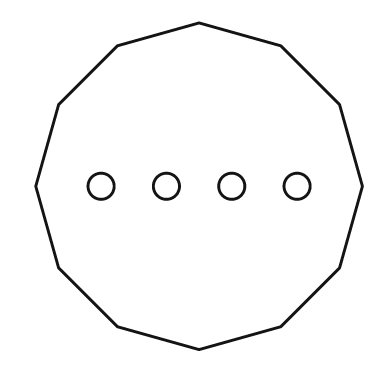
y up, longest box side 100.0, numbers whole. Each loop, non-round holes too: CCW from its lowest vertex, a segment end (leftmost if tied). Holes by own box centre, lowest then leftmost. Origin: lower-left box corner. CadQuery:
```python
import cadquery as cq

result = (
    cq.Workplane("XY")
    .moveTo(50.0, 0.0)
    .lineTo(75.0, 7.0)
    .lineTo(93.0, 25.0)
    .lineTo(100.0, 50.0)
    .lineTo(93.0, 75.0)
    .lineTo(75.0, 93.0)
    .lineTo(50.0, 100.0)
    .lineTo(25.0, 93.0)
    .lineTo(7.0, 75.0)
    .lineTo(0.0, 50.0)
    .lineTo(7.0, 25.0)
    .lineTo(25.0, 7.0)
    .close()
    .moveTo(20.0, 50.0)
    .circle(4.0)
    .moveTo(40.0, 50.0)
    .circle(4.0)
    .moveTo(60.0, 50.0)
    .circle(4.0)
    .moveTo(80.0, 50.0)
    .circle(4.0)
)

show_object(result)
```